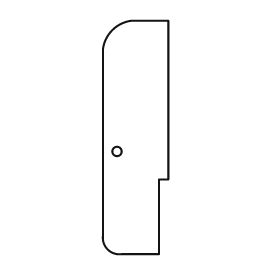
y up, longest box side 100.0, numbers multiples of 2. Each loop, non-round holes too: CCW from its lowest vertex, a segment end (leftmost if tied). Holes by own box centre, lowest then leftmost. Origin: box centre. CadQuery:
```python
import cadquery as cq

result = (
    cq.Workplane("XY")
    .moveTo(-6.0, -50.0)
    .lineTo(10.0, -50.0)
    .lineTo(10.0, -18.0)
    .lineTo(14.0, -18.0)
    .lineTo(14.0, 50.0)
    .lineTo(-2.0, 50.0)
    .threePointArc((-10.0, 46.0), (-14.0, 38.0))
    .lineTo(-14.0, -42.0)
    .threePointArc((-12.0, -48.0), (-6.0, -50.0))
    .close()
    .moveTo(-8.0, -6.0)
    .circle(2.0)
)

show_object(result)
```